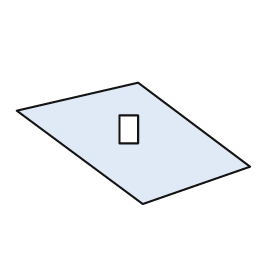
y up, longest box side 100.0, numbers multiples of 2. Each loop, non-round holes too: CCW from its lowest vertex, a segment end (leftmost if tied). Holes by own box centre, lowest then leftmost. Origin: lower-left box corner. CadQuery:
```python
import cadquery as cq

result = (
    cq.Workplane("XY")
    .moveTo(54.0, 0.0)
    .lineTo(100.0, 16.0)
    .lineTo(52.0, 52.0)
    .lineTo(0.0, 40.0)
    .close()
    .moveTo(44.0, 26.0)
    .lineTo(52.0, 26.0)
    .lineTo(52.0, 38.0)
    .lineTo(44.0, 38.0)
    .close()
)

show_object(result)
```